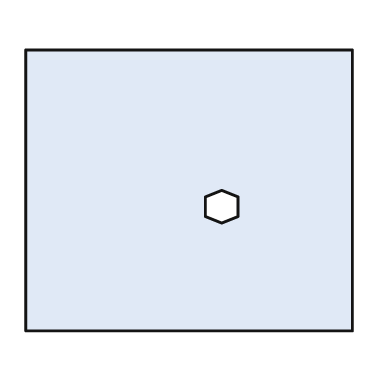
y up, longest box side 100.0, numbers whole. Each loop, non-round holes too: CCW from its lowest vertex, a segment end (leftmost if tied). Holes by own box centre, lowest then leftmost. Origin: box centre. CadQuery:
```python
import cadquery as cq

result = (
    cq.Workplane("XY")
    .moveTo(-50.0, -43.0)
    .lineTo(50.0, -43.0)
    .lineTo(50.0, 43.0)
    .lineTo(-50.0, 43.0)
    .close()
    .moveTo(10.0, -10.0)
    .lineTo(15.0, -8.0)
    .lineTo(15.0, -2.0)
    .lineTo(10.0, 0.0)
    .lineTo(5.0, -2.0)
    .lineTo(5.0, -8.0)
    .close()
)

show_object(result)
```